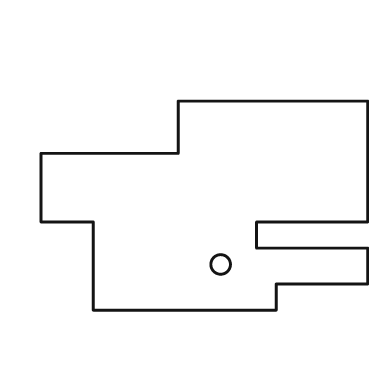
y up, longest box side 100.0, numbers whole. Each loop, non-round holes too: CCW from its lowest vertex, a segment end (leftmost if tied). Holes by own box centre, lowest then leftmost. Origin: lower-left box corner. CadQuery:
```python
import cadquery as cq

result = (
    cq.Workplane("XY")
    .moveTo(16.0, 0.0)
    .lineTo(72.0, 0.0)
    .lineTo(72.0, 8.0)
    .lineTo(100.0, 8.0)
    .lineTo(100.0, 19.0)
    .lineTo(66.0, 19.0)
    .lineTo(66.0, 27.0)
    .lineTo(100.0, 27.0)
    .lineTo(100.0, 64.0)
    .lineTo(42.0, 64.0)
    .lineTo(42.0, 48.0)
    .lineTo(0.0, 48.0)
    .lineTo(0.0, 27.0)
    .lineTo(16.0, 27.0)
    .close()
    .moveTo(55.0, 14.0)
    .circle(3.0)
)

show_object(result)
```